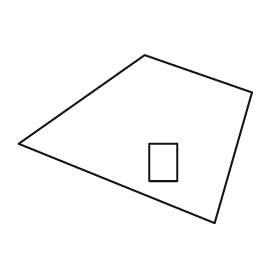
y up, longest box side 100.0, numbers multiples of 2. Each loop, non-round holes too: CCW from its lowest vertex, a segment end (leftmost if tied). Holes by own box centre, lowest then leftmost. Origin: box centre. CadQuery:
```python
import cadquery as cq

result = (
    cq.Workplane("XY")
    .moveTo(34.0, -36.0)
    .lineTo(50.0, 20.0)
    .lineTo(4.0, 36.0)
    .lineTo(-50.0, -2.0)
    .close()
    .moveTo(6.0, -18.0)
    .lineTo(18.0, -18.0)
    .lineTo(18.0, -2.0)
    .lineTo(6.0, -2.0)
    .close()
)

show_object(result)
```